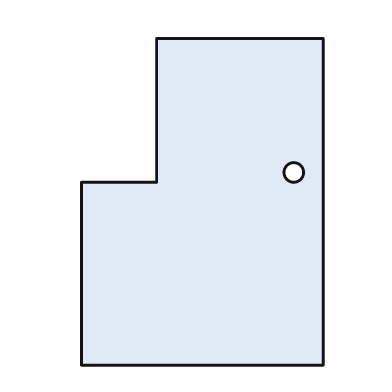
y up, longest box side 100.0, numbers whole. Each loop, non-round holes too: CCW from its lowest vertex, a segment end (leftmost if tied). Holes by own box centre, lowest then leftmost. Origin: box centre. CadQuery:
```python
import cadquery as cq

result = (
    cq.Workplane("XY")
    .moveTo(-37.0, -50.0)
    .lineTo(37.0, -50.0)
    .lineTo(37.0, 50.0)
    .lineTo(-14.0, 50.0)
    .lineTo(-14.0, 6.0)
    .lineTo(-37.0, 6.0)
    .close()
    .moveTo(28.0, 9.0)
    .circle(3.0)
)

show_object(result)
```